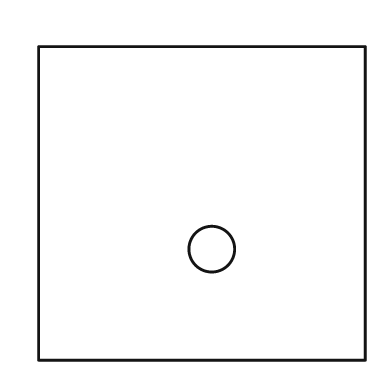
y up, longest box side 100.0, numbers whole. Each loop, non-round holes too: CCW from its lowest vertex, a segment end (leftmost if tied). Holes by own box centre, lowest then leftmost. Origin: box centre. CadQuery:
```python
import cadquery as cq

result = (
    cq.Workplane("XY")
    .moveTo(-50.0, -48.0)
    .lineTo(50.0, -48.0)
    .lineTo(50.0, 48.0)
    .lineTo(-50.0, 48.0)
    .close()
    .moveTo(3.0, -14.0)
    .circle(7.0)
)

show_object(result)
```